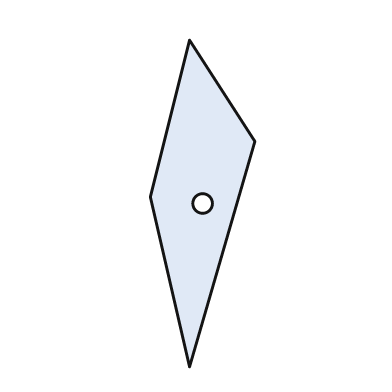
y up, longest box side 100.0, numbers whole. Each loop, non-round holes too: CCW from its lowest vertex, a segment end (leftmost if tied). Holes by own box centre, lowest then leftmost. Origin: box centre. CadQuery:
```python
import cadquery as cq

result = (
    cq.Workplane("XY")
    .moveTo(-4.0, -50.0)
    .lineTo(16.0, 19.0)
    .lineTo(-4.0, 50.0)
    .lineTo(-16.0, 2.0)
    .close()
    .moveTo(0.0, 0.0)
    .circle(3.0)
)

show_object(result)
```